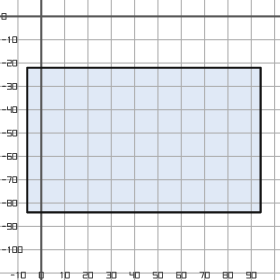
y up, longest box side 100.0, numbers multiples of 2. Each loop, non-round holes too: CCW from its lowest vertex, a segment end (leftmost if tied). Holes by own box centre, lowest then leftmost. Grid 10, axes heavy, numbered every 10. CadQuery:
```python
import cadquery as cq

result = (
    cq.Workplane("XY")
    .moveTo(-6.0, -84.0)
    .lineTo(94.0, -84.0)
    .lineTo(94.0, -22.0)
    .lineTo(-6.0, -22.0)
    .close()
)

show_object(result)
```